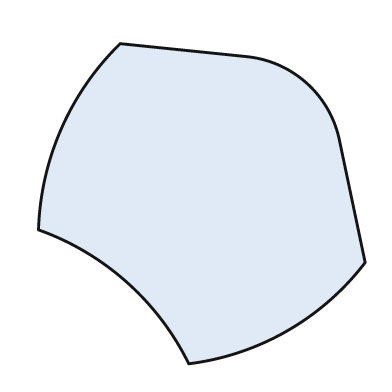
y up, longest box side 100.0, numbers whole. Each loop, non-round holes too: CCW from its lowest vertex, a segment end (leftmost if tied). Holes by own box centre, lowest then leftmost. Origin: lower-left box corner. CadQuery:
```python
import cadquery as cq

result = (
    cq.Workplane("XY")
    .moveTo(46.0, 0.0)
    .threePointArc((76.0, 10.0), (100.0, 31.0))
    .lineTo(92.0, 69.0)
    .threePointArc((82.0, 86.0), (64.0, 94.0))
    .lineTo(25.0, 98.0)
    .threePointArc((7.0, 72.0), (0.0, 41.0))
    .threePointArc((27.0, 25.0), (46.0, 0.0))
    .close()
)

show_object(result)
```